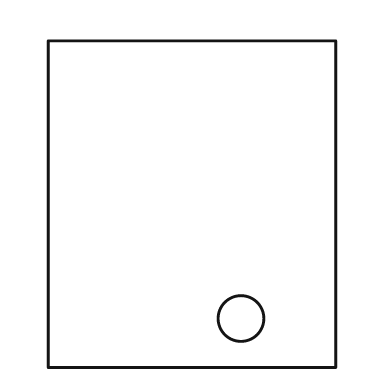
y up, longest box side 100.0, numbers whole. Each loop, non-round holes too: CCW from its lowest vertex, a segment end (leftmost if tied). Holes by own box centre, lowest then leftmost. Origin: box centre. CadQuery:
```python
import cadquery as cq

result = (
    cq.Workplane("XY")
    .moveTo(-44.0, -50.0)
    .lineTo(44.0, -50.0)
    .lineTo(44.0, 50.0)
    .lineTo(-44.0, 50.0)
    .close()
    .moveTo(15.0, -35.0)
    .circle(7.0)
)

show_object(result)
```